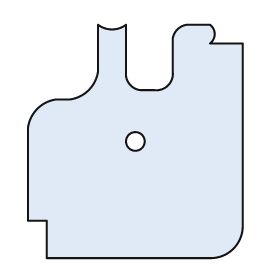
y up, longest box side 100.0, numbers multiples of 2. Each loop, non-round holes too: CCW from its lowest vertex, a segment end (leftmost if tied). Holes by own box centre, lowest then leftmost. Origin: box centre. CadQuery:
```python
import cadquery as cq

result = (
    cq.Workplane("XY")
    .moveTo(-38.0, -50.0)
    .lineTo(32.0, -50.0)
    .threePointArc((42.0, -46.0), (46.0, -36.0))
    .lineTo(46.0, 42.0)
    .lineTo(32.0, 42.0)
    .threePointArc((34.0, 46.0), (32.0, 50.0))
    .lineTo(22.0, 50.0)
    .threePointArc((18.0, 48.0), (16.0, 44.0))
    .lineTo(16.0, 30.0)
    .threePointArc((14.0, 24.0), (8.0, 22.0))
    .lineTo(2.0, 22.0)
    .threePointArc((-2.0, 24.0), (-4.0, 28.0))
    .lineTo(-4.0, 50.0)
    .threePointArc((-10.0, 48.0), (-16.0, 50.0))
    .lineTo(-16.0, 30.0)
    .threePointArc((-20.0, 22.0), (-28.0, 18.0))
    .lineTo(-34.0, 18.0)
    .threePointArc((-42.0, 14.0), (-46.0, 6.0))
    .lineTo(-46.0, -34.0)
    .lineTo(-38.0, -34.0)
    .close()
    .moveTo(0.0, 0.0)
    .circle(4.0)
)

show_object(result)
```